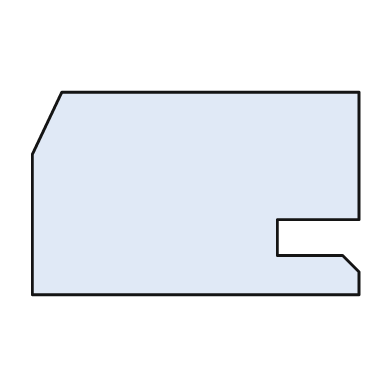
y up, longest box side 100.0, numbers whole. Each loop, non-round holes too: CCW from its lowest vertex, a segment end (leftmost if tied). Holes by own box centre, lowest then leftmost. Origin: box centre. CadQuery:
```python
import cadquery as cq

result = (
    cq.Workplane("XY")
    .moveTo(-50.0, -31.0)
    .lineTo(50.0, -31.0)
    .lineTo(50.0, -24.0)
    .lineTo(45.0, -19.0)
    .lineTo(25.0, -19.0)
    .lineTo(25.0, -8.0)
    .lineTo(50.0, -8.0)
    .lineTo(50.0, 31.0)
    .lineTo(-41.0, 31.0)
    .lineTo(-50.0, 12.0)
    .close()
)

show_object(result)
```